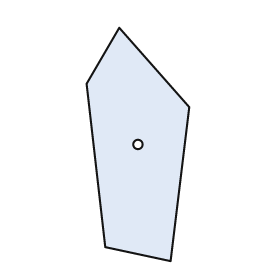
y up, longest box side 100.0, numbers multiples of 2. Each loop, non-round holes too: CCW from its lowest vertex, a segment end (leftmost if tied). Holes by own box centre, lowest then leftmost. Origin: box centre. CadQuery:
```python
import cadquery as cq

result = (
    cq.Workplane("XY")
    .moveTo(14.0, -50.0)
    .lineTo(22.0, 16.0)
    .lineTo(-8.0, 50.0)
    .lineTo(-22.0, 26.0)
    .lineTo(-14.0, -44.0)
    .close()
    .moveTo(0.0, 0.0)
    .circle(2.0)
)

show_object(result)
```